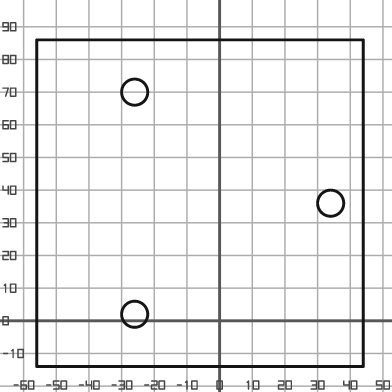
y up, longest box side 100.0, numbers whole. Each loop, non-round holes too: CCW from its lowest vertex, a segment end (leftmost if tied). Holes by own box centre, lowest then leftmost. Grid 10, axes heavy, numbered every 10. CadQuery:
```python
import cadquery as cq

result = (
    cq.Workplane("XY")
    .moveTo(-56.0, -14.0)
    .lineTo(44.0, -14.0)
    .lineTo(44.0, 86.0)
    .lineTo(-56.0, 86.0)
    .close()
    .moveTo(-26.0, 2.0)
    .circle(4.0)
    .moveTo(34.0, 36.0)
    .circle(4.0)
    .moveTo(-26.0, 70.0)
    .circle(4.0)
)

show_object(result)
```